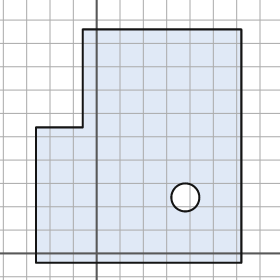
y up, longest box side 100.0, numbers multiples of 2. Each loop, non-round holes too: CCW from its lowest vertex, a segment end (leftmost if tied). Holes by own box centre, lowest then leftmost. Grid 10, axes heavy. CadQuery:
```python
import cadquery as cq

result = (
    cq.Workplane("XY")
    .moveTo(-26.0, -4.0)
    .lineTo(62.0, -4.0)
    .lineTo(62.0, 96.0)
    .lineTo(-6.0, 96.0)
    .lineTo(-6.0, 54.0)
    .lineTo(-26.0, 54.0)
    .close()
    .moveTo(38.0, 24.0)
    .circle(6.0)
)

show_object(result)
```